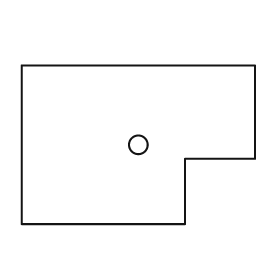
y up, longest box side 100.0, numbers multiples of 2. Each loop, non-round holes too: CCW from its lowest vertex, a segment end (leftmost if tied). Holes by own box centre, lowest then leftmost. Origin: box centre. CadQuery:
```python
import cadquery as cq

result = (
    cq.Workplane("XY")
    .moveTo(-50.0, -34.0)
    .lineTo(20.0, -34.0)
    .lineTo(20.0, -6.0)
    .lineTo(50.0, -6.0)
    .lineTo(50.0, 34.0)
    .lineTo(-50.0, 34.0)
    .close()
    .moveTo(0.0, 0.0)
    .circle(4.0)
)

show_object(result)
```